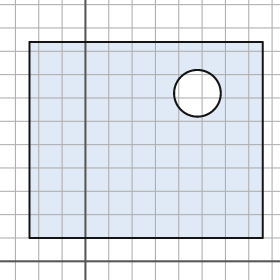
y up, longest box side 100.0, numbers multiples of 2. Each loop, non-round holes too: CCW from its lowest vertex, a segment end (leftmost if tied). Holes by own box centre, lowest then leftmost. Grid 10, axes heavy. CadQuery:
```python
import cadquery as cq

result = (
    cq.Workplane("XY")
    .moveTo(-24.0, 10.0)
    .lineTo(76.0, 10.0)
    .lineTo(76.0, 94.0)
    .lineTo(-24.0, 94.0)
    .close()
    .moveTo(48.0, 72.0)
    .circle(10.0)
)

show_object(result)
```